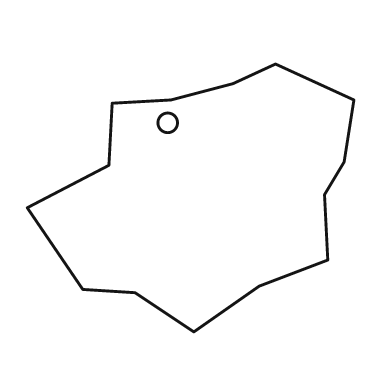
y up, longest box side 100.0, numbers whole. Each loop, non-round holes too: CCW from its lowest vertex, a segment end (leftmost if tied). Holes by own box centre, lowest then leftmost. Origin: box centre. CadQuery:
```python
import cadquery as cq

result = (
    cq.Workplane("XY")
    .moveTo(1.0, -41.0)
    .lineTo(21.0, -27.0)
    .lineTo(42.0, -19.0)
    .lineTo(41.0, 1.0)
    .lineTo(47.0, 11.0)
    .lineTo(50.0, 30.0)
    .lineTo(26.0, 41.0)
    .lineTo(13.0, 35.0)
    .lineTo(-6.0, 30.0)
    .lineTo(-24.0, 29.0)
    .lineTo(-25.0, 10.0)
    .lineTo(-50.0, -3.0)
    .lineTo(-33.0, -28.0)
    .lineTo(-17.0, -29.0)
    .close()
    .moveTo(-7.0, 23.0)
    .circle(3.0)
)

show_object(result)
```